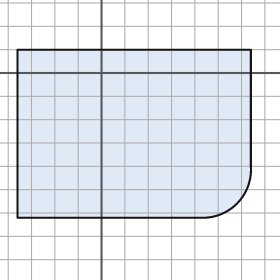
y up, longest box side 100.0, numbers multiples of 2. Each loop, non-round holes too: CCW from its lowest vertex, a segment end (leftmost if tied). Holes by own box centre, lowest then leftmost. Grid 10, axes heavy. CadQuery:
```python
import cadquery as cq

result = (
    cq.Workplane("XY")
    .moveTo(-36.0, -62.0)
    .lineTo(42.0, -62.0)
    .threePointArc((58.0, -56.0), (64.0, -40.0))
    .lineTo(64.0, 10.0)
    .lineTo(-36.0, 10.0)
    .close()
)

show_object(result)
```